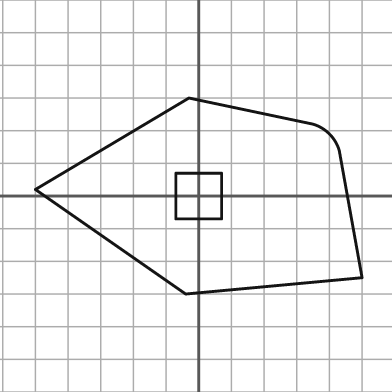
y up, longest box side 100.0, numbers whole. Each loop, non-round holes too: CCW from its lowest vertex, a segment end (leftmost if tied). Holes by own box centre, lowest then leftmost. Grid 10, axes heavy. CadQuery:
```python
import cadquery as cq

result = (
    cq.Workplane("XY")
    .moveTo(-4.0, -30.0)
    .lineTo(50.0, -25.0)
    .lineTo(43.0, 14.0)
    .threePointArc((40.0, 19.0), (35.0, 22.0))
    .lineTo(-3.0, 30.0)
    .lineTo(-50.0, 2.0)
    .close()
    .moveTo(-7.0, -7.0)
    .lineTo(7.0, -7.0)
    .lineTo(7.0, 7.0)
    .lineTo(-7.0, 7.0)
    .close()
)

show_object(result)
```